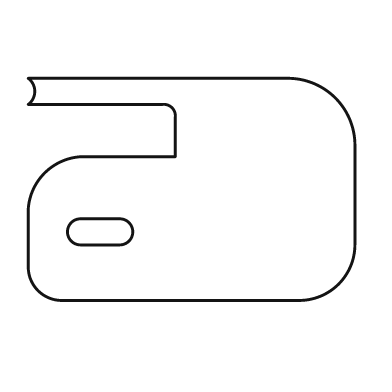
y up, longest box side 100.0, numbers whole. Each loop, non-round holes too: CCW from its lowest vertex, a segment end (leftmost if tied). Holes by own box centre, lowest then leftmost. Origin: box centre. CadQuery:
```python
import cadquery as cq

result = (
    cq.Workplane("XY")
    .moveTo(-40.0, -34.0)
    .lineTo(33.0, -34.0)
    .threePointArc((45.0, -29.0), (50.0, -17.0))
    .lineTo(50.0, 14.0)
    .threePointArc((44.0, 28.0), (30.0, 34.0))
    .lineTo(-50.0, 34.0)
    .threePointArc((-48.0, 30.0), (-50.0, 26.0))
    .lineTo(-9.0, 26.0)
    .threePointArc((-6.0, 25.0), (-5.0, 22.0))
    .lineTo(-5.0, 10.0)
    .lineTo(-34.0, 10.0)
    .threePointArc((-45.0, 5.0), (-50.0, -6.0))
    .lineTo(-50.0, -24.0)
    .threePointArc((-47.0, -31.0), (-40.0, -34.0))
    .close()
    .moveTo(-34.0, -17.0)
    .lineTo(-22.0, -17.0)
    .threePointArc((-18.0, -13.0), (-22.0, -9.0))
    .lineTo(-34.0, -9.0)
    .threePointArc((-38.0, -13.0), (-34.0, -17.0))
    .close()
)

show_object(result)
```